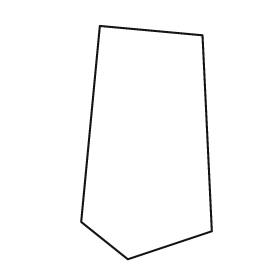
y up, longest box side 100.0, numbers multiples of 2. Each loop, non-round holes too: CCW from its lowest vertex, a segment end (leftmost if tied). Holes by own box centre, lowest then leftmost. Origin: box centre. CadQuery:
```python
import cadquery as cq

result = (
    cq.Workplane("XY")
    .moveTo(-8.0, -50.0)
    .lineTo(28.0, -38.0)
    .lineTo(24.0, 46.0)
    .lineTo(-20.0, 50.0)
    .lineTo(-28.0, -34.0)
    .close()
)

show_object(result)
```